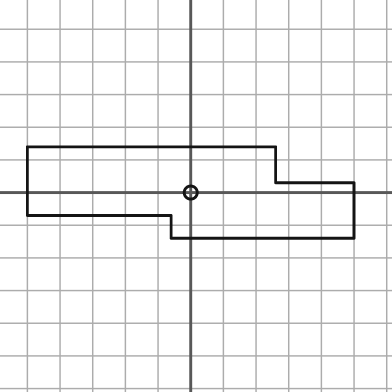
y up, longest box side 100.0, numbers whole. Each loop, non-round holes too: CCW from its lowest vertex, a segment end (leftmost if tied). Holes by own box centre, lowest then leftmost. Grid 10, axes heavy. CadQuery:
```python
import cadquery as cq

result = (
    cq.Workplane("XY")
    .moveTo(-6.0, -14.0)
    .lineTo(50.0, -14.0)
    .lineTo(50.0, 3.0)
    .lineTo(26.0, 3.0)
    .lineTo(26.0, 14.0)
    .lineTo(-50.0, 14.0)
    .lineTo(-50.0, -7.0)
    .lineTo(-6.0, -7.0)
    .close()
    .moveTo(0.0, 0.0)
    .circle(2.0)
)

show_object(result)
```